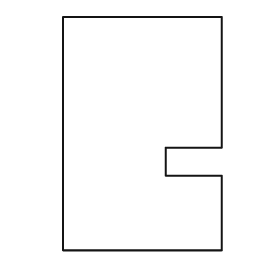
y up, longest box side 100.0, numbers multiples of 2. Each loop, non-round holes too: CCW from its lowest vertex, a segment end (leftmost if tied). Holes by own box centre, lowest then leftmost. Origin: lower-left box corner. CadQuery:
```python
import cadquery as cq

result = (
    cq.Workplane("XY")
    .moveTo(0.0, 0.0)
    .lineTo(68.0, 0.0)
    .lineTo(68.0, 32.0)
    .lineTo(44.0, 32.0)
    .lineTo(44.0, 44.0)
    .lineTo(68.0, 44.0)
    .lineTo(68.0, 100.0)
    .lineTo(0.0, 100.0)
    .close()
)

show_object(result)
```